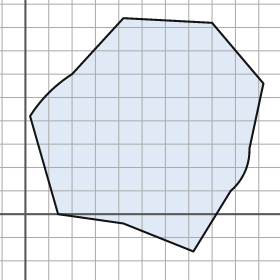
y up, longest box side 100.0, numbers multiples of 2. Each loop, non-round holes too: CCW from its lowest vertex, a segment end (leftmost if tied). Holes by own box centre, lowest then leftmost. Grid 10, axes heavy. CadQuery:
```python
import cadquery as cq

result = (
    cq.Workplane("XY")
    .moveTo(72.0, -16.0)
    .lineTo(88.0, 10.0)
    .threePointArc((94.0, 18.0), (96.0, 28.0))
    .lineTo(102.0, 56.0)
    .lineTo(80.0, 82.0)
    .lineTo(42.0, 84.0)
    .lineTo(20.0, 60.0)
    .threePointArc((10.0, 52.0), (2.0, 42.0))
    .lineTo(14.0, 0.0)
    .lineTo(42.0, -4.0)
    .close()
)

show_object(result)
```